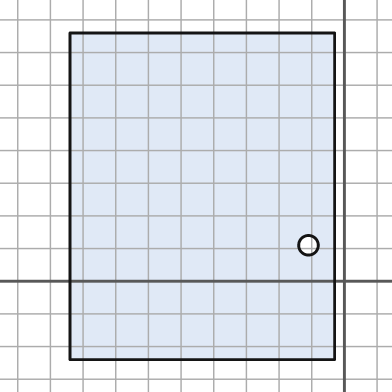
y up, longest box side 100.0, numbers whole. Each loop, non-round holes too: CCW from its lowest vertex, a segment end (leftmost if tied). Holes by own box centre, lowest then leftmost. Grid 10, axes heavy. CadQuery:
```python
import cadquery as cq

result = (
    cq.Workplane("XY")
    .moveTo(-84.0, -24.0)
    .lineTo(-3.0, -24.0)
    .lineTo(-3.0, 76.0)
    .lineTo(-84.0, 76.0)
    .close()
    .moveTo(-11.0, 11.0)
    .circle(3.0)
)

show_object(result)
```